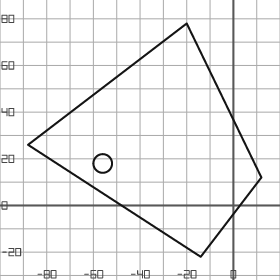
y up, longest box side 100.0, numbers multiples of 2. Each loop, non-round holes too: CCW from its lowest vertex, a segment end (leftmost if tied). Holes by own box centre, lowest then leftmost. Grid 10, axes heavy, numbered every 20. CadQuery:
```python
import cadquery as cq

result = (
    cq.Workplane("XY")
    .moveTo(-14.0, -22.0)
    .lineTo(12.0, 12.0)
    .lineTo(-20.0, 78.0)
    .lineTo(-88.0, 26.0)
    .close()
    .moveTo(-56.0, 18.0)
    .circle(4.0)
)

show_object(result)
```